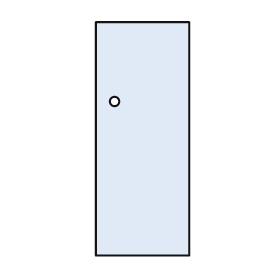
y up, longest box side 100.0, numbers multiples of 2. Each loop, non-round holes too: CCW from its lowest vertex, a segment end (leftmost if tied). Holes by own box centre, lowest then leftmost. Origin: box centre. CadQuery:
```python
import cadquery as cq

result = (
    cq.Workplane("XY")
    .moveTo(-20.0, -50.0)
    .lineTo(20.0, -50.0)
    .lineTo(20.0, 50.0)
    .lineTo(-20.0, 50.0)
    .close()
    .moveTo(-12.0, 16.0)
    .circle(2.0)
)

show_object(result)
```